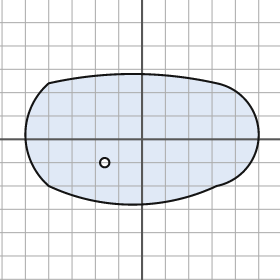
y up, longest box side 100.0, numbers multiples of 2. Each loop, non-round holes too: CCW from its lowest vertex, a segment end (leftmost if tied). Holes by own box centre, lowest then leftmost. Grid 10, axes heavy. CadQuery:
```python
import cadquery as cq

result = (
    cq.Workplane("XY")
    .moveTo(-40.0, -20.0)
    .threePointArc((-4.0, -28.0), (32.0, -20.0))
    .threePointArc((50.0, 2.0), (32.0, 24.0))
    .threePointArc((-4.0, 28.0), (-40.0, 24.0))
    .threePointArc((-50.0, 2.0), (-40.0, -20.0))
    .close()
    .moveTo(-16.0, -10.0)
    .circle(2.0)
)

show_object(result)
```